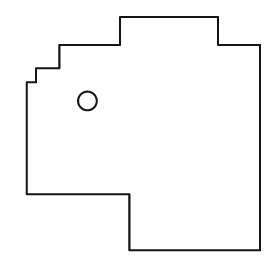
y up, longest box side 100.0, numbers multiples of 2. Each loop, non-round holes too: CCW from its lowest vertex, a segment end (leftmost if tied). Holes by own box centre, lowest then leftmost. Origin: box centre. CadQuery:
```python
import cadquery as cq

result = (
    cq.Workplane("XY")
    .moveTo(-6.0, -50.0)
    .lineTo(50.0, -50.0)
    .lineTo(50.0, 38.0)
    .lineTo(32.0, 38.0)
    .lineTo(32.0, 50.0)
    .lineTo(-10.0, 50.0)
    .lineTo(-10.0, 38.0)
    .lineTo(-36.0, 38.0)
    .lineTo(-36.0, 28.0)
    .lineTo(-46.0, 28.0)
    .lineTo(-46.0, 22.0)
    .lineTo(-50.0, 22.0)
    .lineTo(-50.0, -26.0)
    .lineTo(-6.0, -26.0)
    .close()
    .moveTo(-24.0, 14.0)
    .circle(4.0)
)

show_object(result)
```